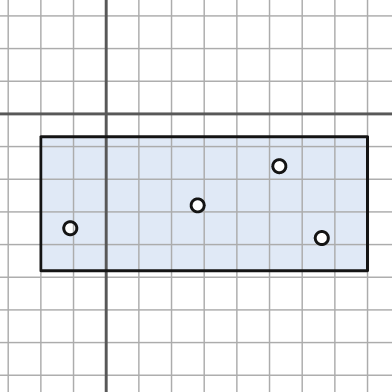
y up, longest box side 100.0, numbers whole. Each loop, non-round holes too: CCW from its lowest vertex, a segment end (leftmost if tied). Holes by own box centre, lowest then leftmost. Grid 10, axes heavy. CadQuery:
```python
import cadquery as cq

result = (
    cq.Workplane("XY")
    .moveTo(-20.0, -48.0)
    .lineTo(80.0, -48.0)
    .lineTo(80.0, -7.0)
    .lineTo(-20.0, -7.0)
    .close()
    .moveTo(66.0, -38.0)
    .circle(2.0)
    .moveTo(-11.0, -35.0)
    .circle(2.0)
    .moveTo(28.0, -28.0)
    .circle(2.0)
    .moveTo(53.0, -16.0)
    .circle(2.0)
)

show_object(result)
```